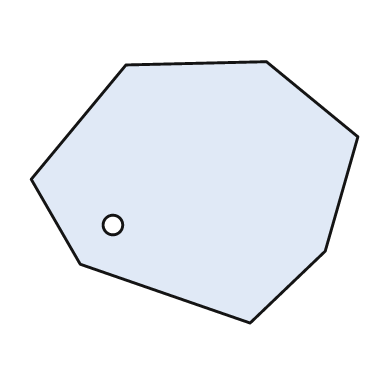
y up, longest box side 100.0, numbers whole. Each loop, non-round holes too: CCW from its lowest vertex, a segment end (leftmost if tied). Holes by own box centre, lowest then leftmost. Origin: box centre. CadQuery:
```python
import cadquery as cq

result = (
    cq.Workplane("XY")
    .moveTo(17.0, -40.0)
    .lineTo(40.0, -18.0)
    .lineTo(50.0, 17.0)
    .lineTo(22.0, 40.0)
    .lineTo(-21.0, 39.0)
    .lineTo(-50.0, 4.0)
    .lineTo(-35.0, -22.0)
    .close()
    .moveTo(-25.0, -10.0)
    .circle(3.0)
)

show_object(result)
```